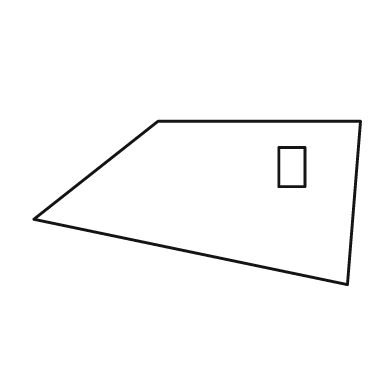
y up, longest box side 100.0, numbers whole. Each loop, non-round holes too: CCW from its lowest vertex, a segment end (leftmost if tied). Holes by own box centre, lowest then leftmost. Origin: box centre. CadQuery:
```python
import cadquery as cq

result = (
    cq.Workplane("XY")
    .moveTo(46.0, -25.0)
    .lineTo(50.0, 25.0)
    .lineTo(-12.0, 25.0)
    .lineTo(-50.0, -5.0)
    .close()
    .moveTo(25.0, 5.0)
    .lineTo(33.0, 5.0)
    .lineTo(33.0, 17.0)
    .lineTo(25.0, 17.0)
    .close()
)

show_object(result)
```